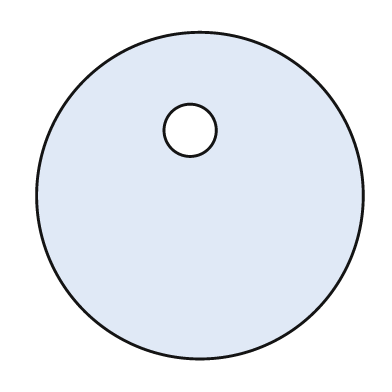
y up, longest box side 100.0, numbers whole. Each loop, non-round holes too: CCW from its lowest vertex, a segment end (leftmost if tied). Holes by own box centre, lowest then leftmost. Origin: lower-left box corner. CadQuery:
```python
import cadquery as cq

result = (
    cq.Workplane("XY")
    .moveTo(50.0, 50.0)
    .circle(50.0)
    .moveTo(47.0, 70.0)
    .circle(8.0)
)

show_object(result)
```